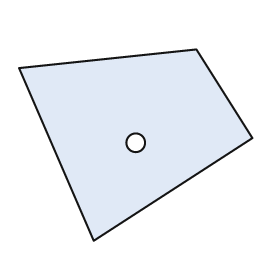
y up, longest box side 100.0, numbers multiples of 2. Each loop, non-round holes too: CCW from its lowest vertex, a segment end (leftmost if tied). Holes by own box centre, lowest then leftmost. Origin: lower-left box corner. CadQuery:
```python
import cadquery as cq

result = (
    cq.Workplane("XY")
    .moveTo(32.0, 0.0)
    .lineTo(100.0, 44.0)
    .lineTo(76.0, 82.0)
    .lineTo(0.0, 74.0)
    .close()
    .moveTo(50.0, 42.0)
    .circle(4.0)
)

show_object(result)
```